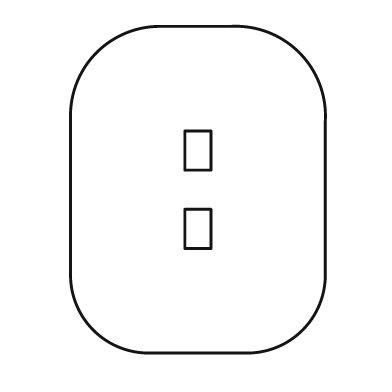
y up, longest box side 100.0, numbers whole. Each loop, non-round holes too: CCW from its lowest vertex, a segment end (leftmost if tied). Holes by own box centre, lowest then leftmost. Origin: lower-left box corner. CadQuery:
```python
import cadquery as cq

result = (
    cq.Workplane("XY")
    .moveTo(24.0, 0.0)
    .lineTo(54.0, 0.0)
    .threePointArc((71.0, 7.0), (78.0, 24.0))
    .lineTo(78.0, 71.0)
    .threePointArc((70.0, 92.0), (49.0, 100.0))
    .lineTo(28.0, 100.0)
    .threePointArc((8.0, 92.0), (0.0, 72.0))
    .lineTo(0.0, 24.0)
    .threePointArc((7.0, 7.0), (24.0, 0.0))
    .close()
    .moveTo(35.0, 32.0)
    .lineTo(43.0, 32.0)
    .lineTo(43.0, 44.0)
    .lineTo(35.0, 44.0)
    .close()
    .moveTo(35.0, 56.0)
    .lineTo(43.0, 56.0)
    .lineTo(43.0, 68.0)
    .lineTo(35.0, 68.0)
    .close()
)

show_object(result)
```